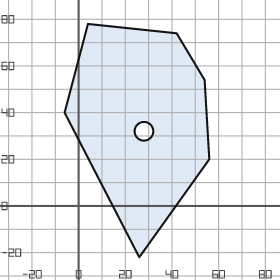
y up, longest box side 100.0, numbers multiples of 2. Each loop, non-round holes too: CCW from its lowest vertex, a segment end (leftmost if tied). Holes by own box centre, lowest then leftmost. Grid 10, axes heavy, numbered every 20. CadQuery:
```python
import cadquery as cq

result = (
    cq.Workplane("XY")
    .moveTo(26.0, -22.0)
    .lineTo(56.0, 20.0)
    .lineTo(54.0, 54.0)
    .lineTo(42.0, 74.0)
    .lineTo(4.0, 78.0)
    .lineTo(-6.0, 40.0)
    .close()
    .moveTo(28.0, 32.0)
    .circle(4.0)
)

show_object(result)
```